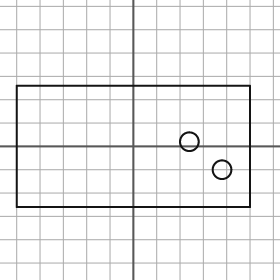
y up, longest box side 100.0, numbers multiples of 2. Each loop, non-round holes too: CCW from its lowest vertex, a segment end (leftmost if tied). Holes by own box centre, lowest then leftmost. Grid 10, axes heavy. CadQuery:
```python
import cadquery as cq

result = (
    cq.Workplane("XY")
    .moveTo(-50.0, -26.0)
    .lineTo(50.0, -26.0)
    .lineTo(50.0, 26.0)
    .lineTo(-50.0, 26.0)
    .close()
    .moveTo(38.0, -10.0)
    .circle(4.0)
    .moveTo(24.0, 2.0)
    .circle(4.0)
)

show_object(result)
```